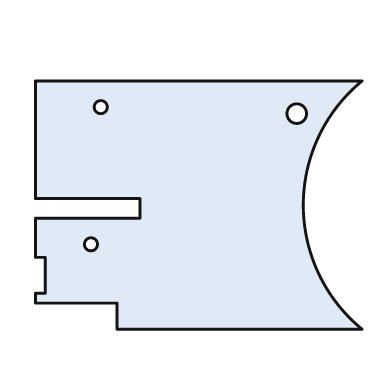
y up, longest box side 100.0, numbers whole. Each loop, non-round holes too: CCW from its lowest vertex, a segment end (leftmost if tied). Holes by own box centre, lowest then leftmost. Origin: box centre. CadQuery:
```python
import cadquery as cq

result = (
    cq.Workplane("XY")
    .moveTo(-25.0, -38.0)
    .lineTo(50.0, -38.0)
    .threePointArc((32.0, 0.0), (50.0, 38.0))
    .lineTo(-50.0, 38.0)
    .lineTo(-50.0, 2.0)
    .lineTo(-18.0, 2.0)
    .lineTo(-18.0, -4.0)
    .lineTo(-50.0, -4.0)
    .lineTo(-50.0, -16.0)
    .lineTo(-47.0, -16.0)
    .lineTo(-47.0, -27.0)
    .lineTo(-50.0, -27.0)
    .lineTo(-50.0, -30.0)
    .lineTo(-25.0, -30.0)
    .close()
    .moveTo(-33.0, -12.0)
    .circle(2.0)
    .moveTo(30.0, 28.0)
    .circle(3.0)
    .moveTo(-30.0, 30.0)
    .circle(2.0)
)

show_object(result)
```